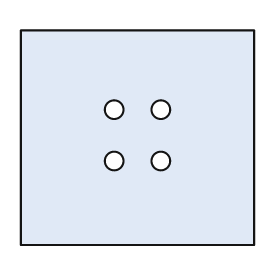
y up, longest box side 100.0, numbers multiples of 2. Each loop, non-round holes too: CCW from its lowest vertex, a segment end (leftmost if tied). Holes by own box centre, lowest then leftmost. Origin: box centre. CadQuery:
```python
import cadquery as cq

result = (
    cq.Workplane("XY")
    .moveTo(-50.0, -46.0)
    .lineTo(50.0, -46.0)
    .lineTo(50.0, 46.0)
    .lineTo(-50.0, 46.0)
    .close()
    .moveTo(-10.0, -10.0)
    .circle(4.0)
    .moveTo(10.0, -10.0)
    .circle(4.0)
    .moveTo(-10.0, 12.0)
    .circle(4.0)
    .moveTo(10.0, 12.0)
    .circle(4.0)
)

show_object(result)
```